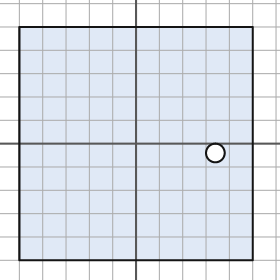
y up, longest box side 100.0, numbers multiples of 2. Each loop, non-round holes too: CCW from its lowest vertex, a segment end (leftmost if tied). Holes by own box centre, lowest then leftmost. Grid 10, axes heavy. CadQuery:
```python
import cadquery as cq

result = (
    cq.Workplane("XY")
    .moveTo(-50.0, -50.0)
    .lineTo(50.0, -50.0)
    .lineTo(50.0, 50.0)
    .lineTo(-50.0, 50.0)
    .close()
    .moveTo(34.0, -4.0)
    .circle(4.0)
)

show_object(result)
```